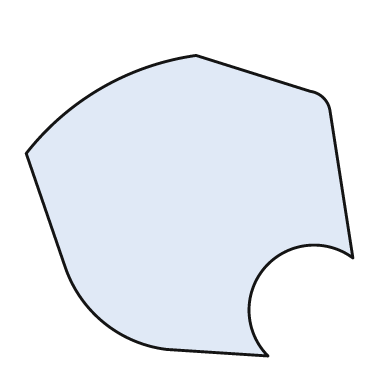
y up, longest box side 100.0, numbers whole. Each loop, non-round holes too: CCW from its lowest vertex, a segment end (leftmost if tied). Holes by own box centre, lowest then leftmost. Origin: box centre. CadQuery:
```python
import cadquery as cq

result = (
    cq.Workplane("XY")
    .moveTo(24.0, -46.0)
    .threePointArc((23.0, -19.0), (50.0, -16.0))
    .lineTo(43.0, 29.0)
    .threePointArc((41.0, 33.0), (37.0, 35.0))
    .lineTo(2.0, 46.0)
    .threePointArc((-27.0, 36.0), (-50.0, 16.0))
    .lineTo(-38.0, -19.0)
    .threePointArc((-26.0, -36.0), (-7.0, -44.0))
    .close()
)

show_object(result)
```